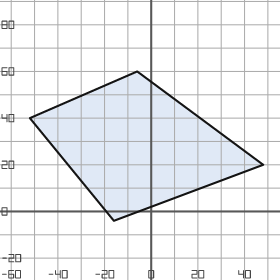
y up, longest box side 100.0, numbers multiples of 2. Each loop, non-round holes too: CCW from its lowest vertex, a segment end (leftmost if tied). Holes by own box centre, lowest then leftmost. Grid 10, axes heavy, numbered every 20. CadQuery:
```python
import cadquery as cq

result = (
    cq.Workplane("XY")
    .moveTo(-16.0, -4.0)
    .lineTo(48.0, 20.0)
    .lineTo(-6.0, 60.0)
    .lineTo(-52.0, 40.0)
    .close()
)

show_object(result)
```